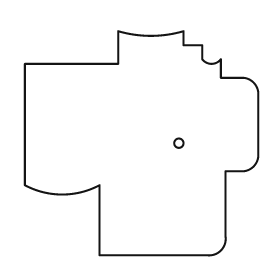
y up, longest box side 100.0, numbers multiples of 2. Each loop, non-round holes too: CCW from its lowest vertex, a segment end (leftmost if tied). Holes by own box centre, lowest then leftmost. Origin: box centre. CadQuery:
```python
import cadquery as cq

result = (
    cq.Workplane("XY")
    .moveTo(-18.0, -48.0)
    .lineTo(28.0, -48.0)
    .threePointArc((34.0, -46.0), (36.0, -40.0))
    .lineTo(36.0, -12.0)
    .lineTo(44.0, -12.0)
    .threePointArc((48.0, -10.0), (50.0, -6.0))
    .lineTo(50.0, 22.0)
    .threePointArc((48.0, 26.0), (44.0, 28.0))
    .lineTo(34.0, 28.0)
    .lineTo(34.0, 36.0)
    .threePointArc((30.0, 34.0), (26.0, 36.0))
    .lineTo(26.0, 42.0)
    .lineTo(18.0, 42.0)
    .lineTo(18.0, 48.0)
    .threePointArc((4.0, 46.0), (-10.0, 48.0))
    .lineTo(-10.0, 34.0)
    .lineTo(-50.0, 34.0)
    .lineTo(-50.0, -18.0)
    .threePointArc((-34.0, -22.0), (-18.0, -18.0))
    .close()
    .moveTo(16.0, 0.0)
    .circle(2.0)
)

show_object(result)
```